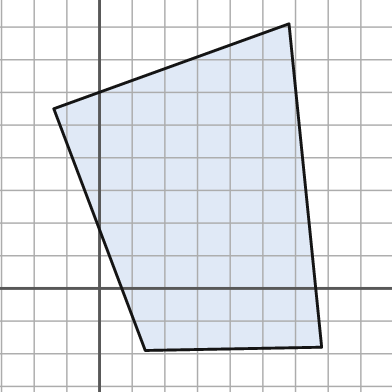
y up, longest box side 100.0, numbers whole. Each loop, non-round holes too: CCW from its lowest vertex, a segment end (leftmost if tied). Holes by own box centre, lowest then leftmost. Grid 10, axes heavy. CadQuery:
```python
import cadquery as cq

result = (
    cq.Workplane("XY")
    .moveTo(14.0, -19.0)
    .lineTo(68.0, -18.0)
    .lineTo(58.0, 81.0)
    .lineTo(-14.0, 55.0)
    .close()
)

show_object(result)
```